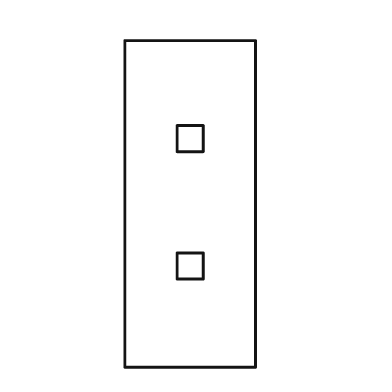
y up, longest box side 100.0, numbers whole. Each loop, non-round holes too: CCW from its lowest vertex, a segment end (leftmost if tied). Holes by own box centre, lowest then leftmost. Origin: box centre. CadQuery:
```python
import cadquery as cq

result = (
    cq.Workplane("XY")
    .moveTo(-20.0, -50.0)
    .lineTo(20.0, -50.0)
    .lineTo(20.0, 50.0)
    .lineTo(-20.0, 50.0)
    .close()
    .moveTo(-4.0, -23.0)
    .lineTo(4.0, -23.0)
    .lineTo(4.0, -15.0)
    .lineTo(-4.0, -15.0)
    .close()
    .moveTo(-4.0, 16.0)
    .lineTo(4.0, 16.0)
    .lineTo(4.0, 24.0)
    .lineTo(-4.0, 24.0)
    .close()
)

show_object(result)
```